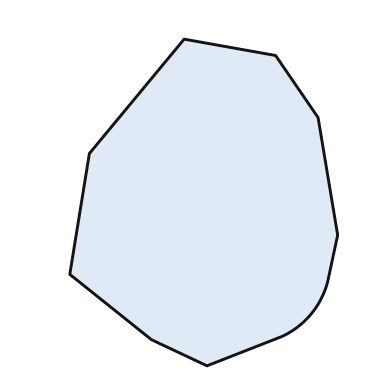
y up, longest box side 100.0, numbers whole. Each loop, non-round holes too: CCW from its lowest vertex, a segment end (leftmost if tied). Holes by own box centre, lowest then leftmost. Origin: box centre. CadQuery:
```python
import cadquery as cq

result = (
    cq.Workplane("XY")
    .moveTo(1.0, -50.0)
    .lineTo(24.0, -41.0)
    .threePointArc((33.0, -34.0), (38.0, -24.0))
    .lineTo(41.0, -10.0)
    .lineTo(35.0, 26.0)
    .lineTo(22.0, 45.0)
    .lineTo(-6.0, 50.0)
    .lineTo(-35.0, 15.0)
    .lineTo(-41.0, -22.0)
    .lineTo(-16.0, -42.0)
    .close()
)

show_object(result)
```